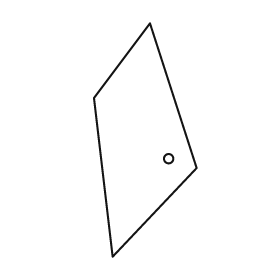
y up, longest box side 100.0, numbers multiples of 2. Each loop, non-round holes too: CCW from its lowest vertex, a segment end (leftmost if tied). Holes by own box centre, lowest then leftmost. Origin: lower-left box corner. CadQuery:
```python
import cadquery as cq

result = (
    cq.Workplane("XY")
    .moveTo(8.0, 0.0)
    .lineTo(44.0, 38.0)
    .lineTo(24.0, 100.0)
    .lineTo(0.0, 68.0)
    .close()
    .moveTo(32.0, 42.0)
    .circle(2.0)
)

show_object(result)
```